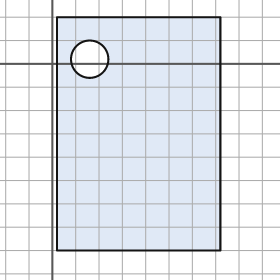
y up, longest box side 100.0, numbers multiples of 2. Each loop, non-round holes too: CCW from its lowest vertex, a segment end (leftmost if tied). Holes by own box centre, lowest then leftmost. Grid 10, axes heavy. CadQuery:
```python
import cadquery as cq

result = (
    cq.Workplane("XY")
    .moveTo(2.0, -80.0)
    .lineTo(72.0, -80.0)
    .lineTo(72.0, 20.0)
    .lineTo(2.0, 20.0)
    .close()
    .moveTo(16.0, 2.0)
    .circle(8.0)
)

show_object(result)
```